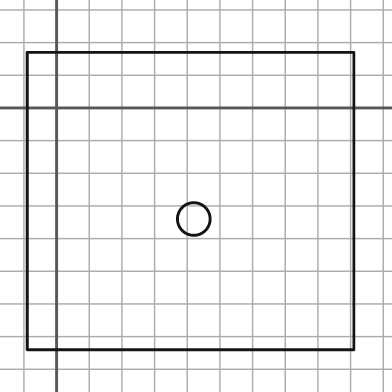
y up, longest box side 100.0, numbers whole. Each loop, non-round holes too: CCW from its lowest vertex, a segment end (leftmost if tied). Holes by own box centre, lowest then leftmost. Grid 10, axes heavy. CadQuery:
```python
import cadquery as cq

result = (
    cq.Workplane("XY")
    .moveTo(-9.0, -74.0)
    .lineTo(91.0, -74.0)
    .lineTo(91.0, 17.0)
    .lineTo(-9.0, 17.0)
    .close()
    .moveTo(42.0, -34.0)
    .circle(5.0)
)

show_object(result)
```